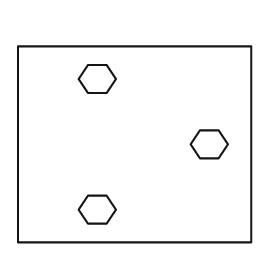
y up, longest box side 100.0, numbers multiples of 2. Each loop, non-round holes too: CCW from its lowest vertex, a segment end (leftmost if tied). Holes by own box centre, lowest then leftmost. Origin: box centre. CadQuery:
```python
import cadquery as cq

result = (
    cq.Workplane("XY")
    .moveTo(-50.0, -42.0)
    .lineTo(50.0, -42.0)
    .lineTo(50.0, 42.0)
    .lineTo(-50.0, 42.0)
    .close()
    .moveTo(-20.0, -34.0)
    .lineTo(-12.0, -34.0)
    .lineTo(-8.0, -28.0)
    .lineTo(-12.0, -22.0)
    .lineTo(-20.0, -22.0)
    .lineTo(-24.0, -28.0)
    .close()
    .moveTo(28.0, -6.0)
    .lineTo(36.0, -6.0)
    .lineTo(40.0, 0.0)
    .lineTo(36.0, 6.0)
    .lineTo(28.0, 6.0)
    .lineTo(24.0, 0.0)
    .close()
    .moveTo(-20.0, 22.0)
    .lineTo(-12.0, 22.0)
    .lineTo(-8.0, 28.0)
    .lineTo(-12.0, 34.0)
    .lineTo(-20.0, 34.0)
    .lineTo(-24.0, 28.0)
    .close()
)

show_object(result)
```